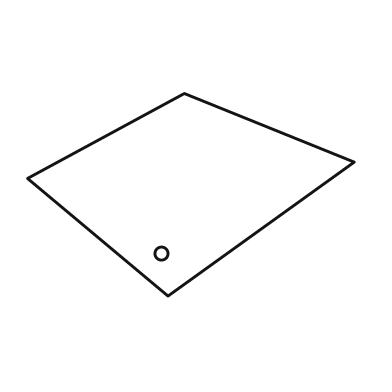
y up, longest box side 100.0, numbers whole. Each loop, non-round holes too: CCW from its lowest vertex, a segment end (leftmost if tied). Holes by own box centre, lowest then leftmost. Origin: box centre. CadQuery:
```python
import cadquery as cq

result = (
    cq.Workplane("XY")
    .moveTo(-7.0, -31.0)
    .lineTo(50.0, 10.0)
    .lineTo(-2.0, 31.0)
    .lineTo(-50.0, 5.0)
    .close()
    .moveTo(-9.0, -18.0)
    .circle(2.0)
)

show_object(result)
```